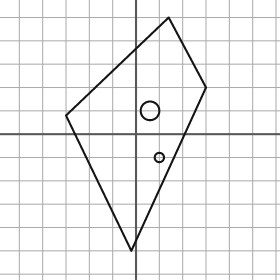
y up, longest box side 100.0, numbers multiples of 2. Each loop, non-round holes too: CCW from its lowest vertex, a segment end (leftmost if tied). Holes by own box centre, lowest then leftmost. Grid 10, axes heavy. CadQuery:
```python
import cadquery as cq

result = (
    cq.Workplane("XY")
    .moveTo(-2.0, -50.0)
    .lineTo(30.0, 20.0)
    .lineTo(14.0, 50.0)
    .lineTo(-30.0, 8.0)
    .close()
    .moveTo(10.0, -10.0)
    .circle(2.0)
    .moveTo(6.0, 10.0)
    .circle(4.0)
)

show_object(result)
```